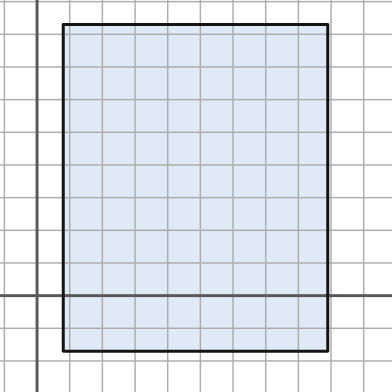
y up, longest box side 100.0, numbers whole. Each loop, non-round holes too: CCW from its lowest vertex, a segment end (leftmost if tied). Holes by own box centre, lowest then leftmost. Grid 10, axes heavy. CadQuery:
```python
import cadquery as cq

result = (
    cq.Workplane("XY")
    .moveTo(8.0, -17.0)
    .lineTo(89.0, -17.0)
    .lineTo(89.0, 83.0)
    .lineTo(8.0, 83.0)
    .close()
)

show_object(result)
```